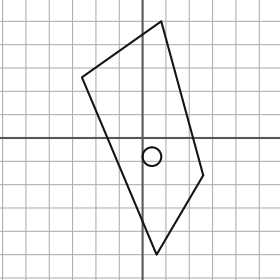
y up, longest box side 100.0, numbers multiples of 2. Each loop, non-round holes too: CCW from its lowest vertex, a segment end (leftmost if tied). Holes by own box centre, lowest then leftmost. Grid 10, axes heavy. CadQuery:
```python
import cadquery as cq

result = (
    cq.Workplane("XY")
    .moveTo(6.0, -50.0)
    .lineTo(26.0, -16.0)
    .lineTo(8.0, 50.0)
    .lineTo(-26.0, 26.0)
    .close()
    .moveTo(4.0, -8.0)
    .circle(4.0)
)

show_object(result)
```